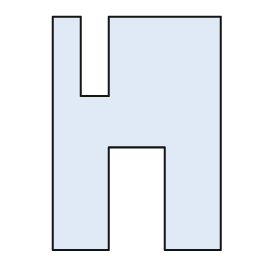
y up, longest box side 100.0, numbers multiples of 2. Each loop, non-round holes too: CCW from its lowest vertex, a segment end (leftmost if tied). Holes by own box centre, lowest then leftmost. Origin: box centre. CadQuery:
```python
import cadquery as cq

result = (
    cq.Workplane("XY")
    .moveTo(-36.0, -50.0)
    .lineTo(-12.0, -50.0)
    .lineTo(-12.0, -6.0)
    .lineTo(12.0, -6.0)
    .lineTo(12.0, -50.0)
    .lineTo(36.0, -50.0)
    .lineTo(36.0, 50.0)
    .lineTo(-12.0, 50.0)
    .lineTo(-12.0, 16.0)
    .lineTo(-24.0, 16.0)
    .lineTo(-24.0, 50.0)
    .lineTo(-36.0, 50.0)
    .close()
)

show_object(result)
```